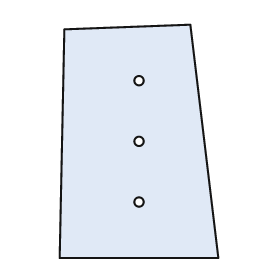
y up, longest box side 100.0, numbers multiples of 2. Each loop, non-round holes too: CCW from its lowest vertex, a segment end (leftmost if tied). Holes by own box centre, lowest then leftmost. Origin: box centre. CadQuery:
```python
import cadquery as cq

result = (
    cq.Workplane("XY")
    .moveTo(-34.0, -50.0)
    .lineTo(34.0, -50.0)
    .lineTo(22.0, 50.0)
    .lineTo(-32.0, 48.0)
    .close()
    .moveTo(0.0, -26.0)
    .circle(2.0)
    .moveTo(0.0, 0.0)
    .circle(2.0)
    .moveTo(0.0, 26.0)
    .circle(2.0)
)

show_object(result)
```